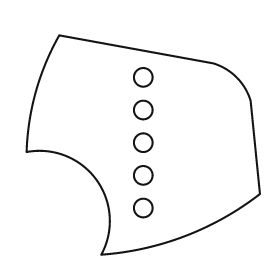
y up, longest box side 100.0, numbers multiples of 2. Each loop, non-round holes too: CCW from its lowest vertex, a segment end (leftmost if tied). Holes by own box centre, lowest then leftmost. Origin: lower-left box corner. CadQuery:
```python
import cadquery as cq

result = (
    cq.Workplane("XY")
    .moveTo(32.0, 0.0)
    .threePointArc((68.0, 8.0), (100.0, 26.0))
    .lineTo(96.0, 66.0)
    .threePointArc((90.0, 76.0), (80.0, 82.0))
    .lineTo(14.0, 94.0)
    .threePointArc((4.0, 70.0), (0.0, 44.0))
    .threePointArc((30.0, 32.0), (32.0, 0.0))
    .close()
    .moveTo(50.0, 20.0)
    .circle(4.0)
    .moveTo(50.0, 34.0)
    .circle(4.0)
    .moveTo(50.0, 48.0)
    .circle(4.0)
    .moveTo(50.0, 62.0)
    .circle(4.0)
    .moveTo(50.0, 76.0)
    .circle(4.0)
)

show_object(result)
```